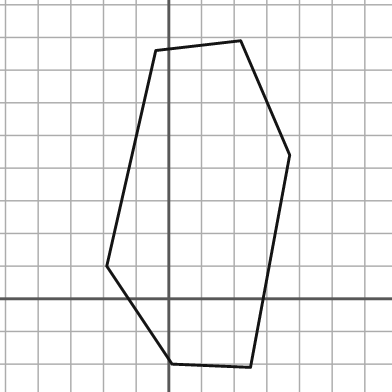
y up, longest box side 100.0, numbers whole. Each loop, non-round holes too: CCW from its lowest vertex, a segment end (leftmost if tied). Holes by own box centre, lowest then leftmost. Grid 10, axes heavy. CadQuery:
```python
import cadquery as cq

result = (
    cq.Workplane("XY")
    .moveTo(25.0, -21.0)
    .lineTo(37.0, 44.0)
    .lineTo(22.0, 79.0)
    .lineTo(-4.0, 76.0)
    .lineTo(-19.0, 10.0)
    .lineTo(1.0, -20.0)
    .close()
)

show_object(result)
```